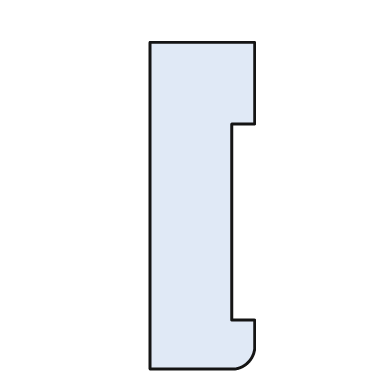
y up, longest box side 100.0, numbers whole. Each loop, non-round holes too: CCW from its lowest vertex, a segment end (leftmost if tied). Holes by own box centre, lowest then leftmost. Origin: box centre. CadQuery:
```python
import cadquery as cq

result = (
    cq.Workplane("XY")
    .moveTo(-16.0, -50.0)
    .lineTo(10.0, -50.0)
    .threePointArc((14.0, -48.0), (16.0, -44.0))
    .lineTo(16.0, -35.0)
    .lineTo(9.0, -35.0)
    .lineTo(9.0, 25.0)
    .lineTo(16.0, 25.0)
    .lineTo(16.0, 50.0)
    .lineTo(-16.0, 50.0)
    .close()
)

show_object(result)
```